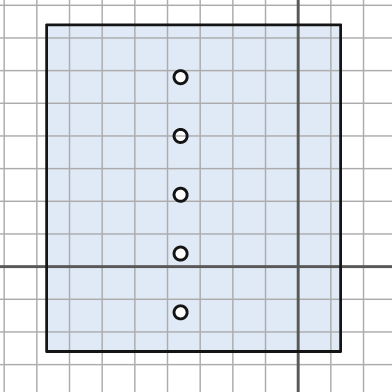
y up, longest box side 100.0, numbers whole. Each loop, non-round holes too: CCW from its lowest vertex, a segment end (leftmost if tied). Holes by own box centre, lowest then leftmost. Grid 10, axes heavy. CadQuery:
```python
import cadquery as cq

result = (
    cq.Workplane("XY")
    .moveTo(-77.0, -26.0)
    .lineTo(13.0, -26.0)
    .lineTo(13.0, 74.0)
    .lineTo(-77.0, 74.0)
    .close()
    .moveTo(-36.0, -14.0)
    .circle(2.0)
    .moveTo(-36.0, 4.0)
    .circle(2.0)
    .moveTo(-36.0, 22.0)
    .circle(2.0)
    .moveTo(-36.0, 40.0)
    .circle(2.0)
    .moveTo(-36.0, 58.0)
    .circle(2.0)
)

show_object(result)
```